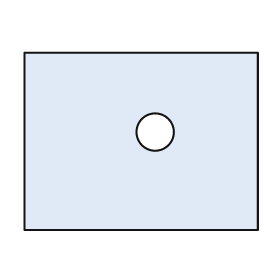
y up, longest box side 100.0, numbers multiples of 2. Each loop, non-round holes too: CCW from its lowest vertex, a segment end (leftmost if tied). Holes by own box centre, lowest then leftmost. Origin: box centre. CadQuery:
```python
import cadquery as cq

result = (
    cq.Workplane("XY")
    .moveTo(-50.0, -38.0)
    .lineTo(50.0, -38.0)
    .lineTo(50.0, 38.0)
    .lineTo(-50.0, 38.0)
    .close()
    .moveTo(6.0, 4.0)
    .circle(8.0)
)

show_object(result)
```